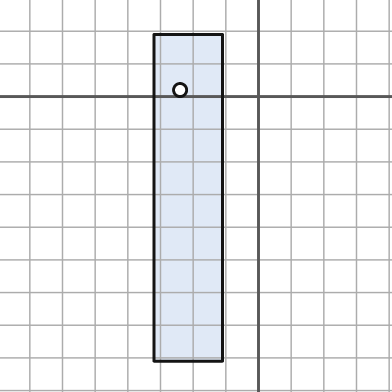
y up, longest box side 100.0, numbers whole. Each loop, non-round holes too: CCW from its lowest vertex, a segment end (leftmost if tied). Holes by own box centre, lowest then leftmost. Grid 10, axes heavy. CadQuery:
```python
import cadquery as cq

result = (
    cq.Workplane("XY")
    .moveTo(-32.0, -81.0)
    .lineTo(-11.0, -81.0)
    .lineTo(-11.0, 19.0)
    .lineTo(-32.0, 19.0)
    .close()
    .moveTo(-24.0, 2.0)
    .circle(2.0)
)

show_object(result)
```